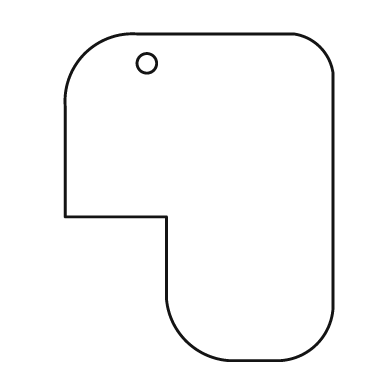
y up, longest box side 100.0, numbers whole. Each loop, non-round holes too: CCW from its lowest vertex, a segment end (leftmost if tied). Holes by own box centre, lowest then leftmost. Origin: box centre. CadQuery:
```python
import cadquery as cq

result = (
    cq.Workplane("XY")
    .moveTo(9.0, -50.0)
    .lineTo(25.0, -50.0)
    .threePointArc((36.0, -45.0), (41.0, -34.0))
    .lineTo(41.0, 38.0)
    .threePointArc((37.0, 46.0), (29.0, 50.0))
    .lineTo(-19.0, 50.0)
    .threePointArc((-35.0, 44.0), (-41.0, 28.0))
    .lineTo(-41.0, -6.0)
    .lineTo(-10.0, -6.0)
    .lineTo(-10.0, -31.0)
    .threePointArc((-4.0, -44.0), (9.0, -50.0))
    .close()
    .moveTo(-16.0, 41.0)
    .circle(3.0)
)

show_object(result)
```